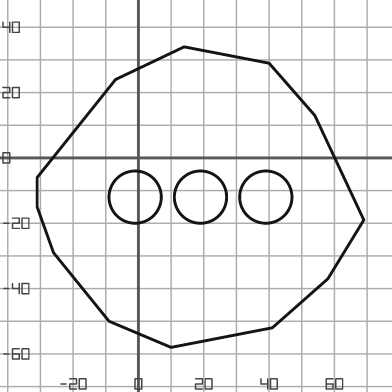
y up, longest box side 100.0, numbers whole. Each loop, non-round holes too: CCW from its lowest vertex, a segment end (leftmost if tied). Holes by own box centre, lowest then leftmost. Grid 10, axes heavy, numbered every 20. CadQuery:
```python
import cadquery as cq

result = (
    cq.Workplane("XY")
    .moveTo(10.0, -58.0)
    .lineTo(41.0, -52.0)
    .lineTo(58.0, -37.0)
    .lineTo(69.0, -19.0)
    .lineTo(54.0, 13.0)
    .lineTo(40.0, 29.0)
    .lineTo(14.0, 34.0)
    .lineTo(-7.0, 24.0)
    .lineTo(-31.0, -6.0)
    .lineTo(-31.0, -15.0)
    .lineTo(-26.0, -29.0)
    .lineTo(-9.0, -50.0)
    .close()
    .moveTo(-1.0, -12.0)
    .circle(8.0)
    .moveTo(19.0, -12.0)
    .circle(8.0)
    .moveTo(39.0, -12.0)
    .circle(8.0)
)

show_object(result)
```